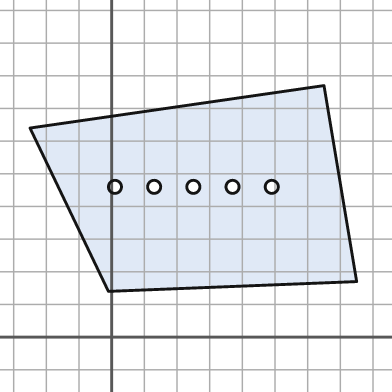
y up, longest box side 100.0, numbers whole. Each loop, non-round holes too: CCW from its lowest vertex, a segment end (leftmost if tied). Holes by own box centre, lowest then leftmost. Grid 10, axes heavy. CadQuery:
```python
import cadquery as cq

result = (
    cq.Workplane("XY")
    .moveTo(-1.0, 14.0)
    .lineTo(75.0, 17.0)
    .lineTo(65.0, 77.0)
    .lineTo(-25.0, 64.0)
    .close()
    .moveTo(1.0, 46.0)
    .circle(2.0)
    .moveTo(13.0, 46.0)
    .circle(2.0)
    .moveTo(25.0, 46.0)
    .circle(2.0)
    .moveTo(37.0, 46.0)
    .circle(2.0)
    .moveTo(49.0, 46.0)
    .circle(2.0)
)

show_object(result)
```